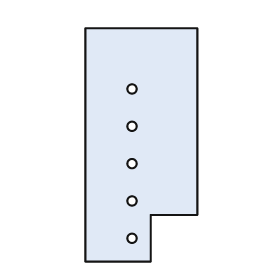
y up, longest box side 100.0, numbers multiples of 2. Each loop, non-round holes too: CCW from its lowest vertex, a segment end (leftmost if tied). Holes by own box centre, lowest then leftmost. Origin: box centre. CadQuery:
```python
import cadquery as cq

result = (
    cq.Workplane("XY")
    .moveTo(-24.0, -50.0)
    .lineTo(4.0, -50.0)
    .lineTo(4.0, -30.0)
    .lineTo(24.0, -30.0)
    .lineTo(24.0, 50.0)
    .lineTo(-24.0, 50.0)
    .close()
    .moveTo(-4.0, -40.0)
    .circle(2.0)
    .moveTo(-4.0, -24.0)
    .circle(2.0)
    .moveTo(-4.0, -8.0)
    .circle(2.0)
    .moveTo(-4.0, 8.0)
    .circle(2.0)
    .moveTo(-4.0, 24.0)
    .circle(2.0)
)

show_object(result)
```